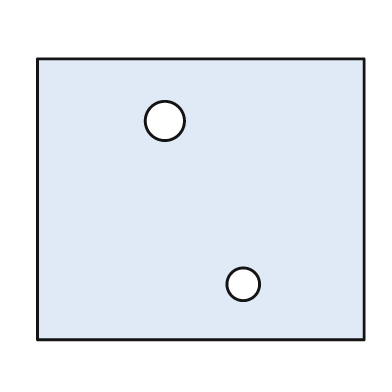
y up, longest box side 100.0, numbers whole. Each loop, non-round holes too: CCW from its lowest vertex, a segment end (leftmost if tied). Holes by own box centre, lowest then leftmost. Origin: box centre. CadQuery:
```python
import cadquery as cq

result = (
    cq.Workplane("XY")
    .moveTo(-50.0, -43.0)
    .lineTo(50.0, -43.0)
    .lineTo(50.0, 43.0)
    .lineTo(-50.0, 43.0)
    .close()
    .moveTo(13.0, -26.0)
    .circle(5.0)
    .moveTo(-11.0, 24.0)
    .circle(6.0)
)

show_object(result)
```